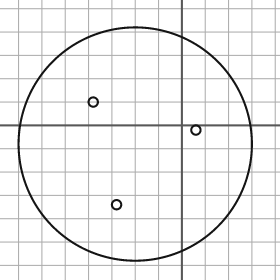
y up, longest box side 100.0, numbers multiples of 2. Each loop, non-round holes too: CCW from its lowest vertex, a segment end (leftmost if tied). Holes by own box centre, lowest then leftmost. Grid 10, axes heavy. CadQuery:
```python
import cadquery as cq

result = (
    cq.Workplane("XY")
    .moveTo(-20.0, -8.0)
    .circle(50.0)
    .moveTo(-28.0, -34.0)
    .circle(2.0)
    .moveTo(6.0, -2.0)
    .circle(2.0)
    .moveTo(-38.0, 10.0)
    .circle(2.0)
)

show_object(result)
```